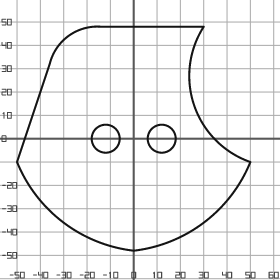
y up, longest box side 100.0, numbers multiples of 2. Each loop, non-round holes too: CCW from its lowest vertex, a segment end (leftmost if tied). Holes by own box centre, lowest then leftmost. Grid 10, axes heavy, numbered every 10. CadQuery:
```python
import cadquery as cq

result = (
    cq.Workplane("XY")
    .moveTo(0.0, -48.0)
    .threePointArc((30.0, -36.0), (50.0, -10.0))
    .threePointArc((26.0, 14.0), (30.0, 48.0))
    .lineTo(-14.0, 48.0)
    .threePointArc((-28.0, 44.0), (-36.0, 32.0))
    .lineTo(-50.0, -10.0)
    .threePointArc((-30.0, -36.0), (0.0, -48.0))
    .close()
    .moveTo(-12.0, 0.0)
    .circle(6.0)
    .moveTo(12.0, 0.0)
    .circle(6.0)
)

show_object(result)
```